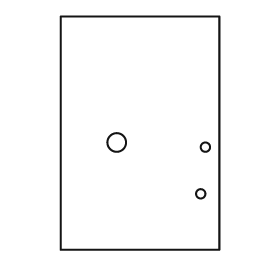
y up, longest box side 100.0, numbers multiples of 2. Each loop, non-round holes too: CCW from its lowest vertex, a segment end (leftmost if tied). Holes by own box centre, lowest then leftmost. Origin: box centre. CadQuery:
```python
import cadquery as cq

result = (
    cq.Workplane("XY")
    .moveTo(-34.0, -50.0)
    .lineTo(34.0, -50.0)
    .lineTo(34.0, 50.0)
    .lineTo(-34.0, 50.0)
    .close()
    .moveTo(26.0, -26.0)
    .circle(2.0)
    .moveTo(28.0, -6.0)
    .circle(2.0)
    .moveTo(-10.0, -4.0)
    .circle(4.0)
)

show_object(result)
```